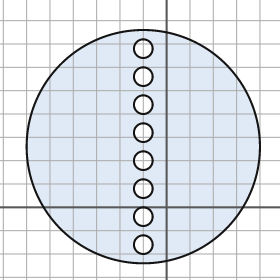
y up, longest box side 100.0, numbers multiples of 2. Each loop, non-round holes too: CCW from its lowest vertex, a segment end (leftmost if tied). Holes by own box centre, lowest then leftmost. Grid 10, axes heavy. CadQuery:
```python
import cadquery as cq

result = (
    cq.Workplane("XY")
    .moveTo(-10.0, 26.0)
    .circle(50.0)
    .moveTo(-10.0, -16.0)
    .circle(4.0)
    .moveTo(-10.0, -4.0)
    .circle(4.0)
    .moveTo(-10.0, 8.0)
    .circle(4.0)
    .moveTo(-10.0, 20.0)
    .circle(4.0)
    .moveTo(-10.0, 32.0)
    .circle(4.0)
    .moveTo(-10.0, 44.0)
    .circle(4.0)
    .moveTo(-10.0, 56.0)
    .circle(4.0)
    .moveTo(-10.0, 68.0)
    .circle(4.0)
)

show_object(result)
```